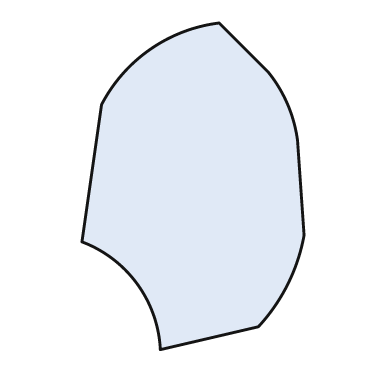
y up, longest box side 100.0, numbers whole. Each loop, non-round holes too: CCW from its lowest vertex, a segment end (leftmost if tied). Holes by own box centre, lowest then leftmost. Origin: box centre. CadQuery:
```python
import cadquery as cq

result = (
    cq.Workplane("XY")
    .moveTo(-10.0, -50.0)
    .lineTo(20.0, -43.0)
    .threePointArc((29.0, -30.0), (34.0, -15.0))
    .lineTo(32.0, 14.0)
    .threePointArc((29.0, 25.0), (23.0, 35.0))
    .lineTo(8.0, 50.0)
    .threePointArc((-13.0, 42.0), (-28.0, 25.0))
    .lineTo(-34.0, -17.0)
    .threePointArc((-17.0, -30.0), (-10.0, -50.0))
    .close()
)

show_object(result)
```